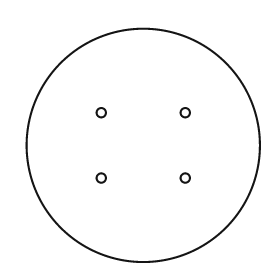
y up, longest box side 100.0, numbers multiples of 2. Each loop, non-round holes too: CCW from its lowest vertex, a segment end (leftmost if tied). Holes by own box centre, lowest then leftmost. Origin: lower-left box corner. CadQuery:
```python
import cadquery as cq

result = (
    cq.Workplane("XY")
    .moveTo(50.0, 50.0)
    .circle(50.0)
    .moveTo(32.0, 36.0)
    .circle(2.0)
    .moveTo(68.0, 36.0)
    .circle(2.0)
    .moveTo(32.0, 64.0)
    .circle(2.0)
    .moveTo(68.0, 64.0)
    .circle(2.0)
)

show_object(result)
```